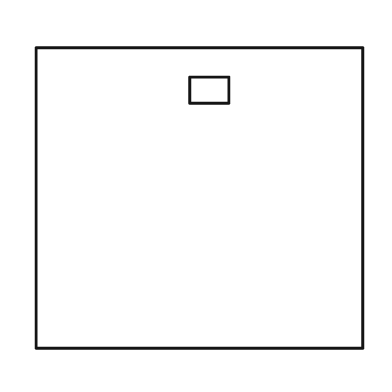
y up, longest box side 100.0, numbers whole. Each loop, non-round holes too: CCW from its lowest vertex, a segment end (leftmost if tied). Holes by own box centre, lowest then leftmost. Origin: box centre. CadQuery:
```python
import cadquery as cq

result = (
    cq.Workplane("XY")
    .moveTo(-50.0, -46.0)
    .lineTo(50.0, -46.0)
    .lineTo(50.0, 46.0)
    .lineTo(-50.0, 46.0)
    .close()
    .moveTo(-3.0, 29.0)
    .lineTo(9.0, 29.0)
    .lineTo(9.0, 37.0)
    .lineTo(-3.0, 37.0)
    .close()
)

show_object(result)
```